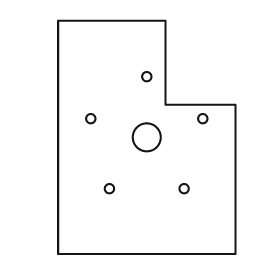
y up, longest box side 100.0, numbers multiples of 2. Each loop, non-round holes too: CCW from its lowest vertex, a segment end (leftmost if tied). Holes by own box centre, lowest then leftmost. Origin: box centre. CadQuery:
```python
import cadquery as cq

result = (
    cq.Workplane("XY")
    .moveTo(-38.0, -50.0)
    .lineTo(38.0, -50.0)
    .lineTo(38.0, 14.0)
    .lineTo(8.0, 14.0)
    .lineTo(8.0, 50.0)
    .lineTo(-38.0, 50.0)
    .close()
    .moveTo(-16.0, -22.0)
    .circle(2.0)
    .moveTo(16.0, -22.0)
    .circle(2.0)
    .moveTo(0.0, 0.0)
    .circle(6.0)
    .moveTo(-24.0, 8.0)
    .circle(2.0)
    .moveTo(24.0, 8.0)
    .circle(2.0)
    .moveTo(0.0, 26.0)
    .circle(2.0)
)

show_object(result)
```